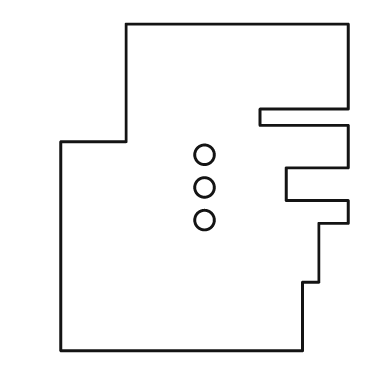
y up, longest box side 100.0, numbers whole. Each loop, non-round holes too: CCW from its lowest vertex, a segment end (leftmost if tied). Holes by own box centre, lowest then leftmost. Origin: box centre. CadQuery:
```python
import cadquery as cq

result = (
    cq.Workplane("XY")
    .moveTo(-44.0, -50.0)
    .lineTo(30.0, -50.0)
    .lineTo(30.0, -29.0)
    .lineTo(35.0, -29.0)
    .lineTo(35.0, -11.0)
    .lineTo(44.0, -11.0)
    .lineTo(44.0, -4.0)
    .lineTo(25.0, -4.0)
    .lineTo(25.0, 6.0)
    .lineTo(44.0, 6.0)
    .lineTo(44.0, 19.0)
    .lineTo(17.0, 19.0)
    .lineTo(17.0, 24.0)
    .lineTo(44.0, 24.0)
    .lineTo(44.0, 50.0)
    .lineTo(-24.0, 50.0)
    .lineTo(-24.0, 14.0)
    .lineTo(-44.0, 14.0)
    .close()
    .moveTo(0.0, -10.0)
    .circle(3.0)
    .moveTo(0.0, 0.0)
    .circle(3.0)
    .moveTo(0.0, 10.0)
    .circle(3.0)
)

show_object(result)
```